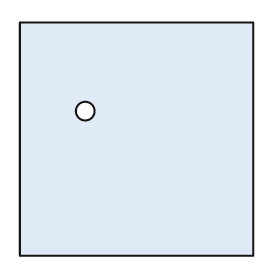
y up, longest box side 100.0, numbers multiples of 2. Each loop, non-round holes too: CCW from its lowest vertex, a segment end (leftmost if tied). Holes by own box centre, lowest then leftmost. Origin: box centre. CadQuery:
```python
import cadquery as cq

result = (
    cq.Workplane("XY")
    .moveTo(-50.0, -50.0)
    .lineTo(50.0, -50.0)
    .lineTo(50.0, 50.0)
    .lineTo(-50.0, 50.0)
    .close()
    .moveTo(-22.0, 12.0)
    .circle(4.0)
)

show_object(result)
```